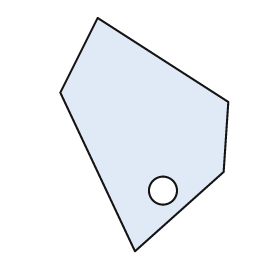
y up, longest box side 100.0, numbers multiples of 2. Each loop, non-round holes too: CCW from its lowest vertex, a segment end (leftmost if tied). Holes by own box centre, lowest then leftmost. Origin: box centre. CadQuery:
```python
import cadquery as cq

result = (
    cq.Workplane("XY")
    .moveTo(-4.0, -50.0)
    .lineTo(34.0, -16.0)
    .lineTo(36.0, 14.0)
    .lineTo(-20.0, 50.0)
    .lineTo(-36.0, 18.0)
    .close()
    .moveTo(8.0, -24.0)
    .circle(6.0)
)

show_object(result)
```